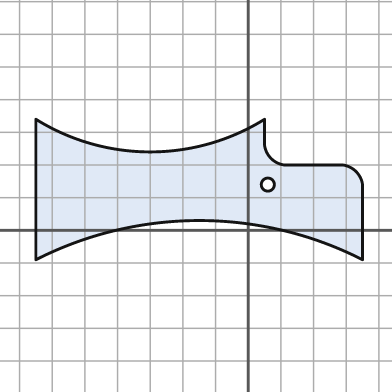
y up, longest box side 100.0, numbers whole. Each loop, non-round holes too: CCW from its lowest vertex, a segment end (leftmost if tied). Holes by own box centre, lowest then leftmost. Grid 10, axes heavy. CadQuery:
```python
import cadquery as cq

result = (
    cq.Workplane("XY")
    .moveTo(-65.0, -9.0)
    .threePointArc((-15.0, 3.0), (35.0, -9.0))
    .lineTo(35.0, 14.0)
    .threePointArc((33.0, 18.0), (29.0, 20.0))
    .lineTo(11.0, 20.0)
    .threePointArc((7.0, 22.0), (5.0, 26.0))
    .lineTo(5.0, 34.0)
    .threePointArc((-30.0, 24.0), (-65.0, 34.0))
    .close()
    .moveTo(6.0, 14.0)
    .circle(2.0)
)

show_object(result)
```